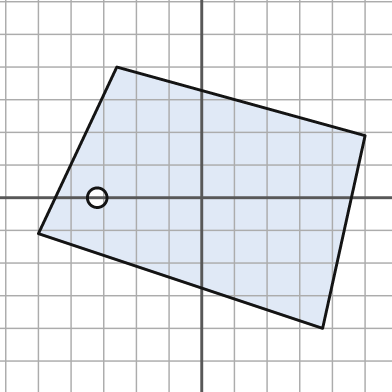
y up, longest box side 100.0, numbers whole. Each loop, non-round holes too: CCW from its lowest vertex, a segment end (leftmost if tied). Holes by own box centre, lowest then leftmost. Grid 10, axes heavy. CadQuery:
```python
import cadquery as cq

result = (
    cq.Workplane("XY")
    .moveTo(37.0, -40.0)
    .lineTo(50.0, 19.0)
    .lineTo(-26.0, 40.0)
    .lineTo(-50.0, -11.0)
    .close()
    .moveTo(-32.0, 0.0)
    .circle(3.0)
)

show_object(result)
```